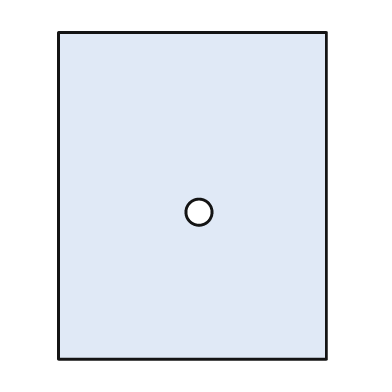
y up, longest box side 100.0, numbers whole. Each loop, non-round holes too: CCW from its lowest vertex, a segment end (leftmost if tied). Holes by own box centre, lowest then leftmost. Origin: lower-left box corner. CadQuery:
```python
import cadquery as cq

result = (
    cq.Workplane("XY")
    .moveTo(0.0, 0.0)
    .lineTo(82.0, 0.0)
    .lineTo(82.0, 100.0)
    .lineTo(0.0, 100.0)
    .close()
    .moveTo(43.0, 45.0)
    .circle(4.0)
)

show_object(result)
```